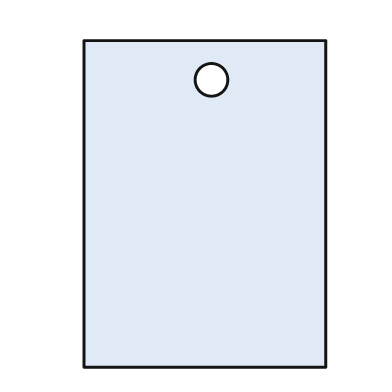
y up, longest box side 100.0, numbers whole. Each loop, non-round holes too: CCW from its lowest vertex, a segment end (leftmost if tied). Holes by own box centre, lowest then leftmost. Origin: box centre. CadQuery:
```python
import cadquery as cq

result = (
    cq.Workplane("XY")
    .moveTo(-37.0, -50.0)
    .lineTo(37.0, -50.0)
    .lineTo(37.0, 50.0)
    .lineTo(-37.0, 50.0)
    .close()
    .moveTo(2.0, 38.0)
    .circle(5.0)
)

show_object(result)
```